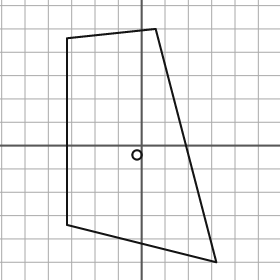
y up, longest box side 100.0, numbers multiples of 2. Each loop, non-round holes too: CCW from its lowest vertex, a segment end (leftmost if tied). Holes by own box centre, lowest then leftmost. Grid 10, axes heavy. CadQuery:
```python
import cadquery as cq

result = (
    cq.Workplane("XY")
    .moveTo(32.0, -50.0)
    .lineTo(6.0, 50.0)
    .lineTo(-32.0, 46.0)
    .lineTo(-32.0, -34.0)
    .close()
    .moveTo(-2.0, -4.0)
    .circle(2.0)
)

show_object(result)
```